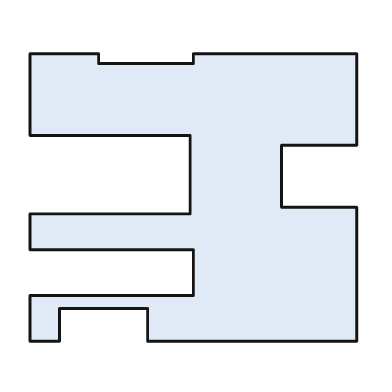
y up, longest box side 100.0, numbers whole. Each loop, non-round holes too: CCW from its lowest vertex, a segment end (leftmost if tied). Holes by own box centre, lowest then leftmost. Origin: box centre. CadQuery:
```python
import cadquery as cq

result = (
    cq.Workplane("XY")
    .moveTo(-50.0, -44.0)
    .lineTo(-41.0, -44.0)
    .lineTo(-41.0, -34.0)
    .lineTo(-14.0, -34.0)
    .lineTo(-14.0, -44.0)
    .lineTo(50.0, -44.0)
    .lineTo(50.0, -3.0)
    .lineTo(27.0, -3.0)
    .lineTo(27.0, 16.0)
    .lineTo(50.0, 16.0)
    .lineTo(50.0, 44.0)
    .lineTo(0.0, 44.0)
    .lineTo(0.0, 41.0)
    .lineTo(-29.0, 41.0)
    .lineTo(-29.0, 44.0)
    .lineTo(-50.0, 44.0)
    .lineTo(-50.0, 19.0)
    .lineTo(-1.0, 19.0)
    .lineTo(-1.0, -5.0)
    .lineTo(-50.0, -5.0)
    .lineTo(-50.0, -16.0)
    .lineTo(0.0, -16.0)
    .lineTo(0.0, -30.0)
    .lineTo(-50.0, -30.0)
    .close()
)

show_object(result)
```